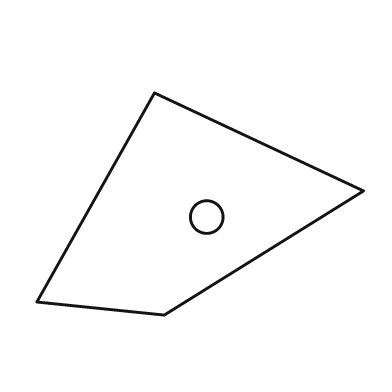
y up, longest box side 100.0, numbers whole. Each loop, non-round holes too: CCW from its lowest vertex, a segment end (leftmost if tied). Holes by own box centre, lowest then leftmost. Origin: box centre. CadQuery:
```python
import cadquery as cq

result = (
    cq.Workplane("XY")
    .moveTo(-11.0, -34.0)
    .lineTo(50.0, 4.0)
    .lineTo(-14.0, 34.0)
    .lineTo(-50.0, -30.0)
    .close()
    .moveTo(2.0, -4.0)
    .circle(5.0)
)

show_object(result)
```